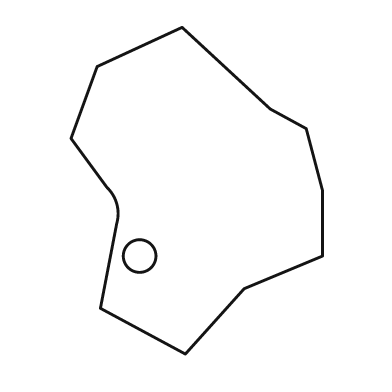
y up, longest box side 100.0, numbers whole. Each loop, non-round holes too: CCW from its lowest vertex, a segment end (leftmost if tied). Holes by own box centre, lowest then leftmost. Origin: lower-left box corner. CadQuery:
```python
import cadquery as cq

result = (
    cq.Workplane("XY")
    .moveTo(35.0, 0.0)
    .lineTo(53.0, 20.0)
    .lineTo(77.0, 30.0)
    .lineTo(77.0, 50.0)
    .lineTo(72.0, 69.0)
    .lineTo(61.0, 75.0)
    .lineTo(34.0, 100.0)
    .lineTo(8.0, 88.0)
    .lineTo(0.0, 66.0)
    .lineTo(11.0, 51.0)
    .threePointArc((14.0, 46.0), (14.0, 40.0))
    .lineTo(9.0, 14.0)
    .close()
    .moveTo(21.0, 30.0)
    .circle(5.0)
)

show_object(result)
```